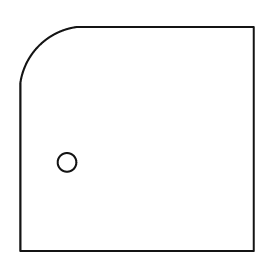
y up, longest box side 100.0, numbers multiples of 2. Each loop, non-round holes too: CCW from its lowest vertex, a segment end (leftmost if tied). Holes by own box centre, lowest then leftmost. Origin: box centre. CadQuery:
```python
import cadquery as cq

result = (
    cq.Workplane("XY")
    .moveTo(-50.0, -48.0)
    .lineTo(50.0, -48.0)
    .lineTo(50.0, 48.0)
    .lineTo(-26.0, 48.0)
    .threePointArc((-42.0, 40.0), (-50.0, 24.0))
    .close()
    .moveTo(-30.0, -10.0)
    .circle(4.0)
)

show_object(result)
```